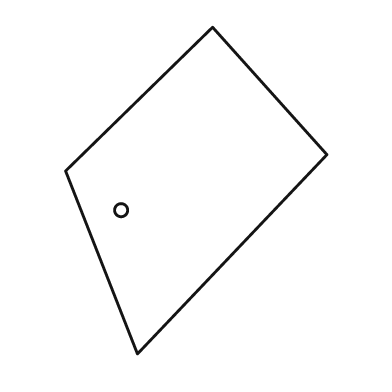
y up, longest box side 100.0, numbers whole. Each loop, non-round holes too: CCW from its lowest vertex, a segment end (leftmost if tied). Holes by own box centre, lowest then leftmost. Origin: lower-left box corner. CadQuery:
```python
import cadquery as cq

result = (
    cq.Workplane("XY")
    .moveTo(22.0, 0.0)
    .lineTo(80.0, 61.0)
    .lineTo(45.0, 100.0)
    .lineTo(0.0, 56.0)
    .close()
    .moveTo(17.0, 44.0)
    .circle(2.0)
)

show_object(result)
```